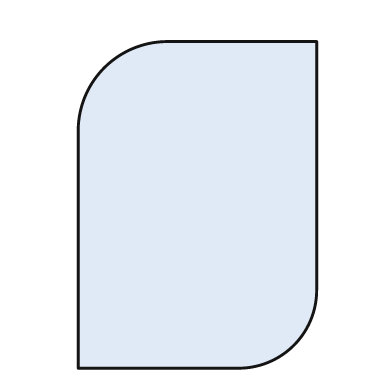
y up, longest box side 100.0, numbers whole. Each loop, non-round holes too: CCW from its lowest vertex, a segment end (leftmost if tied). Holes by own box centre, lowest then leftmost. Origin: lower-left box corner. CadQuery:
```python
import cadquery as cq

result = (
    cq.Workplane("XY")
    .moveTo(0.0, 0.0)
    .lineTo(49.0, 0.0)
    .threePointArc((66.0, 7.0), (73.0, 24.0))
    .lineTo(73.0, 100.0)
    .lineTo(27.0, 100.0)
    .threePointArc((8.0, 92.0), (0.0, 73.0))
    .close()
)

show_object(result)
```